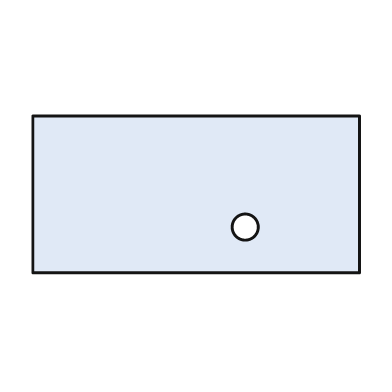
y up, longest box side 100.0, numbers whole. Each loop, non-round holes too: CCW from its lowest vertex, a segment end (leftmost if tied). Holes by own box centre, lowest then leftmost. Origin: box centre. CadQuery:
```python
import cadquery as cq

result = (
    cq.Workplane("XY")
    .moveTo(-50.0, -24.0)
    .lineTo(50.0, -24.0)
    .lineTo(50.0, 24.0)
    .lineTo(-50.0, 24.0)
    .close()
    .moveTo(15.0, -10.0)
    .circle(4.0)
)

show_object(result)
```